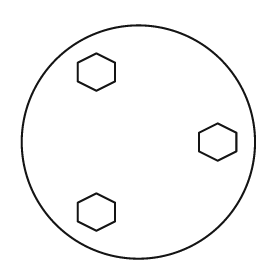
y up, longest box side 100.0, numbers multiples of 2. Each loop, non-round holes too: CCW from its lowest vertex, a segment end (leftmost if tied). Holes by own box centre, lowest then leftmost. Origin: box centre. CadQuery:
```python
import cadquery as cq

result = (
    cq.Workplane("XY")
    .moveTo(0.0, 0.0)
    .circle(50.0)
    .moveTo(-18.0, -38.0)
    .lineTo(-10.0, -34.0)
    .lineTo(-10.0, -26.0)
    .lineTo(-18.0, -22.0)
    .lineTo(-26.0, -26.0)
    .lineTo(-26.0, -34.0)
    .close()
    .moveTo(34.0, -8.0)
    .lineTo(42.0, -4.0)
    .lineTo(42.0, 4.0)
    .lineTo(34.0, 8.0)
    .lineTo(26.0, 4.0)
    .lineTo(26.0, -4.0)
    .close()
    .moveTo(-18.0, 22.0)
    .lineTo(-10.0, 26.0)
    .lineTo(-10.0, 34.0)
    .lineTo(-18.0, 38.0)
    .lineTo(-26.0, 34.0)
    .lineTo(-26.0, 26.0)
    .close()
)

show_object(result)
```